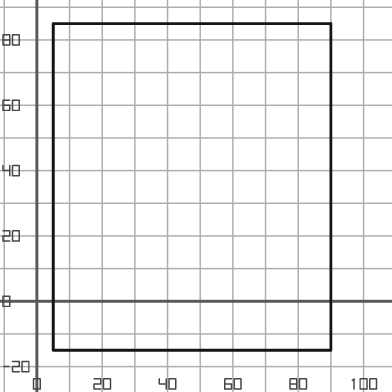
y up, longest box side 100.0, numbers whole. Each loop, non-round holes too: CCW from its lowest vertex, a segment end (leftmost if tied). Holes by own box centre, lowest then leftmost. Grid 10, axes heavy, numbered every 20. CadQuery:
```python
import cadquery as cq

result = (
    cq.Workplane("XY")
    .moveTo(5.0, -15.0)
    .lineTo(90.0, -15.0)
    .lineTo(90.0, 85.0)
    .lineTo(5.0, 85.0)
    .close()
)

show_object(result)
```